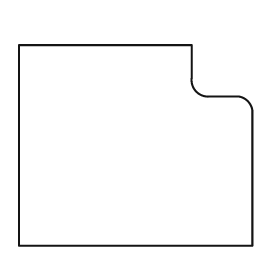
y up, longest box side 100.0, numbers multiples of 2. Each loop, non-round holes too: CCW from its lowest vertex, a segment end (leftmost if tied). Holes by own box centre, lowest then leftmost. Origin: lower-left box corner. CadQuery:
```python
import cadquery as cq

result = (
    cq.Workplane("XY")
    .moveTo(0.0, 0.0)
    .lineTo(100.0, 0.0)
    .lineTo(100.0, 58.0)
    .threePointArc((98.0, 62.0), (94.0, 64.0))
    .lineTo(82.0, 64.0)
    .threePointArc((76.0, 66.0), (74.0, 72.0))
    .lineTo(74.0, 86.0)
    .lineTo(0.0, 86.0)
    .close()
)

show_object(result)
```